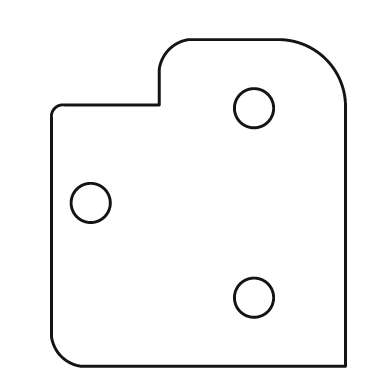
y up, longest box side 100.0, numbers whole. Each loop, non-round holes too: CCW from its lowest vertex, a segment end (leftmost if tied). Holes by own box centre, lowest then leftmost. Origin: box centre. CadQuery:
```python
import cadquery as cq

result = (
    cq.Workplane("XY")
    .moveTo(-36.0, -50.0)
    .lineTo(45.0, -50.0)
    .lineTo(45.0, 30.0)
    .threePointArc((39.0, 44.0), (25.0, 50.0))
    .lineTo(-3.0, 50.0)
    .threePointArc((-9.0, 47.0), (-12.0, 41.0))
    .lineTo(-12.0, 30.0)
    .lineTo(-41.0, 30.0)
    .threePointArc((-44.0, 29.0), (-45.0, 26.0))
    .lineTo(-45.0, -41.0)
    .threePointArc((-42.0, -47.0), (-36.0, -50.0))
    .close()
    .moveTo(17.0, -29.0)
    .circle(6.0)
    .moveTo(-33.0, 0.0)
    .circle(6.0)
    .moveTo(17.0, 29.0)
    .circle(6.0)
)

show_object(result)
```